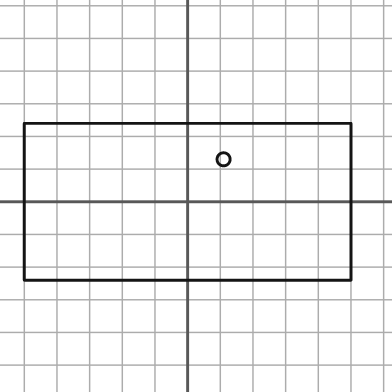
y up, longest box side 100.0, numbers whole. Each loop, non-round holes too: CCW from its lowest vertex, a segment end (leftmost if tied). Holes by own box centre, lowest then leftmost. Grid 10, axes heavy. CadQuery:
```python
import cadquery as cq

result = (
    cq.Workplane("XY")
    .moveTo(-50.0, -24.0)
    .lineTo(50.0, -24.0)
    .lineTo(50.0, 24.0)
    .lineTo(-50.0, 24.0)
    .close()
    .moveTo(11.0, 13.0)
    .circle(2.0)
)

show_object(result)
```